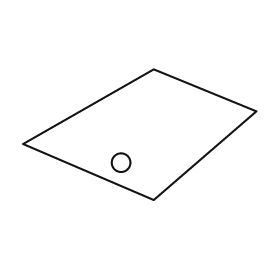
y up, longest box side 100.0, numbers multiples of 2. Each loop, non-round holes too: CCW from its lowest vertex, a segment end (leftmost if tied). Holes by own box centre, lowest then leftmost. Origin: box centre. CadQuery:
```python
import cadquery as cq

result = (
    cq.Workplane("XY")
    .moveTo(6.0, -28.0)
    .lineTo(50.0, 10.0)
    .lineTo(6.0, 28.0)
    .lineTo(-50.0, -4.0)
    .close()
    .moveTo(-8.0, -12.0)
    .circle(4.0)
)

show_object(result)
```